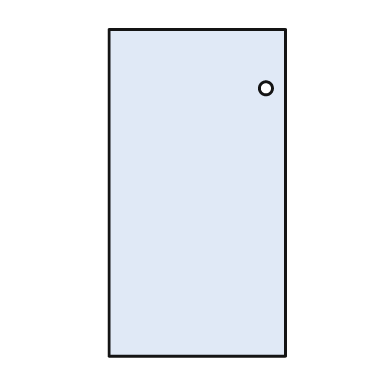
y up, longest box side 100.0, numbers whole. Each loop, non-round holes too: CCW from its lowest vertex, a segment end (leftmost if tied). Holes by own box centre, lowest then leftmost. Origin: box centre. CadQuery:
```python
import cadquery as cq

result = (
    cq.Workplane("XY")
    .moveTo(-27.0, -50.0)
    .lineTo(27.0, -50.0)
    .lineTo(27.0, 50.0)
    .lineTo(-27.0, 50.0)
    .close()
    .moveTo(21.0, 32.0)
    .circle(2.0)
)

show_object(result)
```